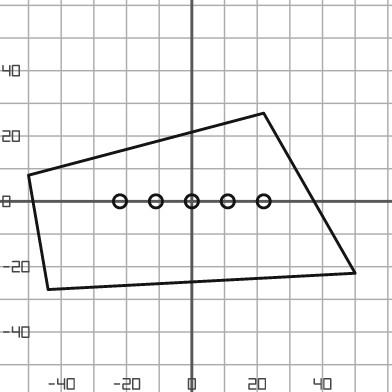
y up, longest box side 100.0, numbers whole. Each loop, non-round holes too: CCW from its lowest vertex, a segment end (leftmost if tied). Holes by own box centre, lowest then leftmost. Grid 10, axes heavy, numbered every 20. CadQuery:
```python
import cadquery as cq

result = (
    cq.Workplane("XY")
    .moveTo(-44.0, -27.0)
    .lineTo(50.0, -22.0)
    .lineTo(22.0, 27.0)
    .lineTo(-50.0, 8.0)
    .close()
    .moveTo(-22.0, 0.0)
    .circle(2.0)
    .moveTo(-11.0, 0.0)
    .circle(2.0)
    .moveTo(0.0, 0.0)
    .circle(2.0)
    .moveTo(11.0, 0.0)
    .circle(2.0)
    .moveTo(22.0, 0.0)
    .circle(2.0)
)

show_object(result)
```